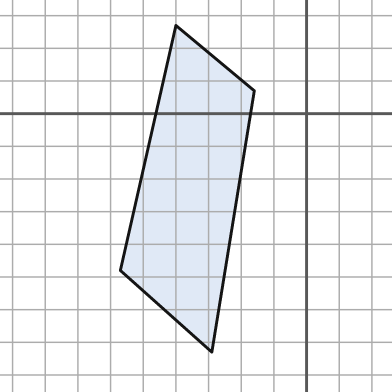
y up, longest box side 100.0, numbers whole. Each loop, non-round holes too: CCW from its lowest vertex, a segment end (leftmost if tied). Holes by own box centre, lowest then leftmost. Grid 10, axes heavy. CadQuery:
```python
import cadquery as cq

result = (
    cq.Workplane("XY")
    .moveTo(-29.0, -73.0)
    .lineTo(-16.0, 7.0)
    .lineTo(-40.0, 27.0)
    .lineTo(-57.0, -48.0)
    .close()
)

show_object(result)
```